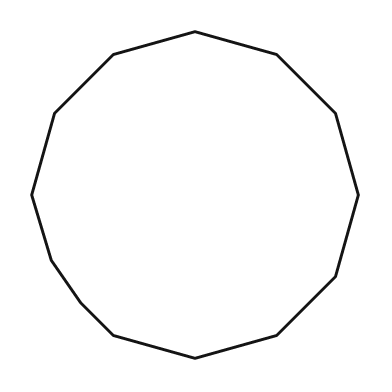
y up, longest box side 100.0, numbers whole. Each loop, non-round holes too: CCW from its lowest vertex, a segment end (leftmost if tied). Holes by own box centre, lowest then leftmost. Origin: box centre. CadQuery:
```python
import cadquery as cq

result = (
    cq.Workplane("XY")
    .moveTo(0.0, -50.0)
    .lineTo(25.0, -43.0)
    .lineTo(43.0, -25.0)
    .lineTo(50.0, 0.0)
    .lineTo(43.0, 25.0)
    .lineTo(25.0, 43.0)
    .lineTo(0.0, 50.0)
    .lineTo(-25.0, 43.0)
    .lineTo(-43.0, 25.0)
    .lineTo(-50.0, 0.0)
    .lineTo(-44.0, -20.0)
    .lineTo(-35.0, -33.0)
    .lineTo(-25.0, -43.0)
    .close()
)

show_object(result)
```